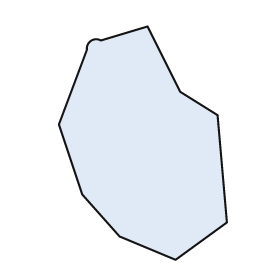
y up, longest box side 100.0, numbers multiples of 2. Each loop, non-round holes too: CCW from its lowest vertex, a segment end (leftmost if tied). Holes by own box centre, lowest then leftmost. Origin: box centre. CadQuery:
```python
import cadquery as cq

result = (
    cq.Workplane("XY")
    .moveTo(14.0, -50.0)
    .lineTo(36.0, -34.0)
    .lineTo(32.0, 12.0)
    .lineTo(16.0, 22.0)
    .lineTo(2.0, 50.0)
    .lineTo(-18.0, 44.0)
    .threePointArc((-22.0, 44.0), (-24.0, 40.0))
    .lineTo(-36.0, 8.0)
    .lineTo(-26.0, -22.0)
    .lineTo(-10.0, -40.0)
    .close()
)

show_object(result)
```